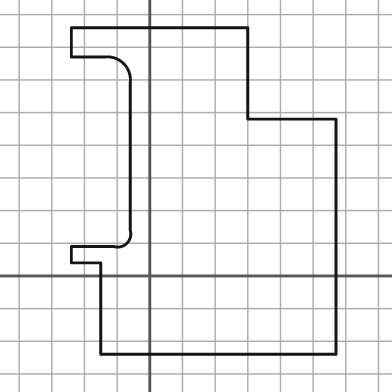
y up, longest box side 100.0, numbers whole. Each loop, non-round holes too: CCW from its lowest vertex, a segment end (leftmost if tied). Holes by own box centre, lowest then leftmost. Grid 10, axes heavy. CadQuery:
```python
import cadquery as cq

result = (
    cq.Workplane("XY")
    .moveTo(-15.0, -24.0)
    .lineTo(57.0, -24.0)
    .lineTo(57.0, 48.0)
    .lineTo(30.0, 48.0)
    .lineTo(30.0, 76.0)
    .lineTo(-24.0, 76.0)
    .lineTo(-24.0, 67.0)
    .lineTo(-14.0, 67.0)
    .threePointArc((-8.0, 65.0), (-6.0, 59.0))
    .lineTo(-6.0, 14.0)
    .threePointArc((-7.0, 10.0), (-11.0, 9.0))
    .lineTo(-24.0, 9.0)
    .lineTo(-24.0, 4.0)
    .lineTo(-15.0, 4.0)
    .close()
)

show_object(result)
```